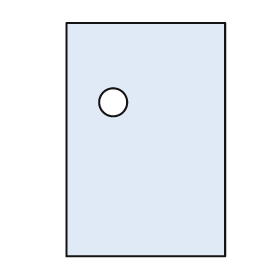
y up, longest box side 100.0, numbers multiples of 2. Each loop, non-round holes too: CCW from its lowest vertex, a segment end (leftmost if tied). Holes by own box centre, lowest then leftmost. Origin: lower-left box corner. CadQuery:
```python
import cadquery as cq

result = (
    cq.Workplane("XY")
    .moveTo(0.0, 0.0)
    .lineTo(68.0, 0.0)
    .lineTo(68.0, 100.0)
    .lineTo(0.0, 100.0)
    .close()
    .moveTo(20.0, 66.0)
    .circle(6.0)
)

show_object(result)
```